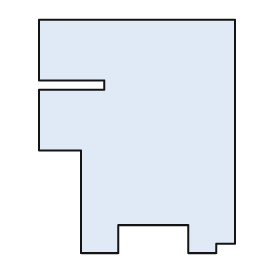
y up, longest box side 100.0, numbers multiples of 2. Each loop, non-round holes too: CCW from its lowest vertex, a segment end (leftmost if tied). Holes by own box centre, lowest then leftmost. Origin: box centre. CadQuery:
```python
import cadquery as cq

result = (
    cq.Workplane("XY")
    .moveTo(-24.0, -50.0)
    .lineTo(-8.0, -50.0)
    .lineTo(-8.0, -38.0)
    .lineTo(22.0, -38.0)
    .lineTo(22.0, -50.0)
    .lineTo(34.0, -50.0)
    .lineTo(34.0, -46.0)
    .lineTo(42.0, -46.0)
    .lineTo(42.0, 50.0)
    .lineTo(-42.0, 50.0)
    .lineTo(-42.0, 24.0)
    .lineTo(-14.0, 24.0)
    .lineTo(-14.0, 20.0)
    .lineTo(-42.0, 20.0)
    .lineTo(-42.0, -6.0)
    .lineTo(-24.0, -6.0)
    .close()
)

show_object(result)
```